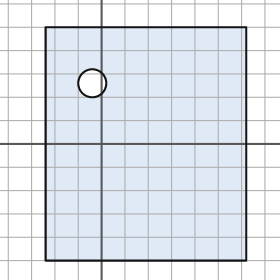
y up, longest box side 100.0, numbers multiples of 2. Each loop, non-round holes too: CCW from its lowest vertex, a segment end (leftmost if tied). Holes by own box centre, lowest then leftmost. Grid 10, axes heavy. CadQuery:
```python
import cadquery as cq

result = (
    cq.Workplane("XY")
    .moveTo(-24.0, -50.0)
    .lineTo(62.0, -50.0)
    .lineTo(62.0, 50.0)
    .lineTo(-24.0, 50.0)
    .close()
    .moveTo(-4.0, 26.0)
    .circle(6.0)
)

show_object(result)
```